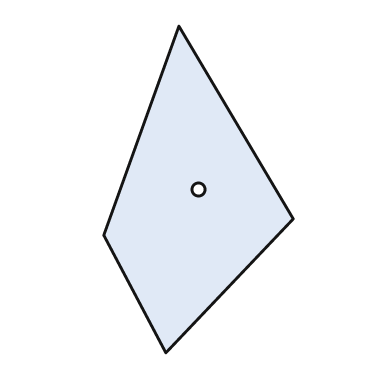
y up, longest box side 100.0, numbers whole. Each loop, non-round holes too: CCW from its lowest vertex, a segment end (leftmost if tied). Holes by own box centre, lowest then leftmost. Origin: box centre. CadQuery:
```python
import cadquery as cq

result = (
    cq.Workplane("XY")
    .moveTo(-10.0, -50.0)
    .lineTo(29.0, -9.0)
    .lineTo(-6.0, 50.0)
    .lineTo(-29.0, -14.0)
    .close()
    .moveTo(0.0, 0.0)
    .circle(2.0)
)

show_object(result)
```